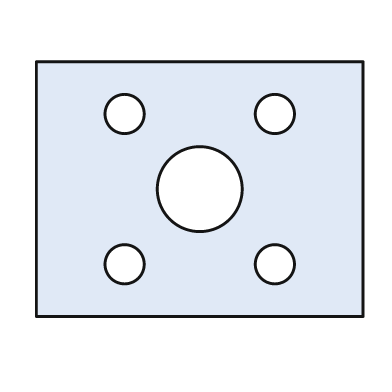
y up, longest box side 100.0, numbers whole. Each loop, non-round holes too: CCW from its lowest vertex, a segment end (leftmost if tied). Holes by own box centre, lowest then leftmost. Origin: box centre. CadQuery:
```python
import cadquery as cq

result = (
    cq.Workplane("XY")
    .moveTo(-50.0, -39.0)
    .lineTo(50.0, -39.0)
    .lineTo(50.0, 39.0)
    .lineTo(-50.0, 39.0)
    .close()
    .moveTo(-23.0, -23.0)
    .circle(6.0)
    .moveTo(23.0, -23.0)
    .circle(6.0)
    .moveTo(0.0, 0.0)
    .circle(13.0)
    .moveTo(-23.0, 23.0)
    .circle(6.0)
    .moveTo(23.0, 23.0)
    .circle(6.0)
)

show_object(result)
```